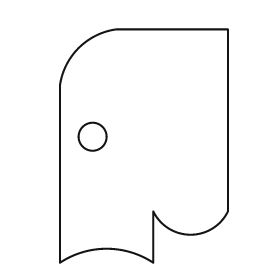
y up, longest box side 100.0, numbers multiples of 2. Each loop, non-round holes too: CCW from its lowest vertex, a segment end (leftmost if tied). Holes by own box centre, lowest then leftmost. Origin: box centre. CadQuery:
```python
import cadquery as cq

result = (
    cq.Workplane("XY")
    .moveTo(-36.0, -50.0)
    .threePointArc((-16.0, -44.0), (4.0, -50.0))
    .lineTo(4.0, -28.0)
    .threePointArc((20.0, -38.0), (36.0, -28.0))
    .lineTo(36.0, 50.0)
    .lineTo(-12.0, 50.0)
    .threePointArc((-28.0, 42.0), (-36.0, 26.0))
    .close()
    .moveTo(-22.0, 4.0)
    .circle(6.0)
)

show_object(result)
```